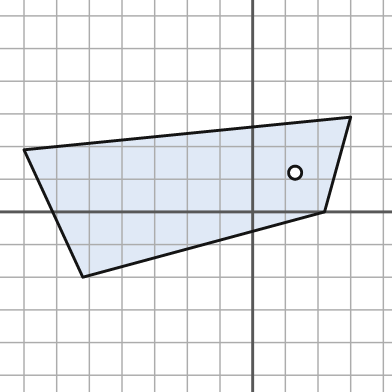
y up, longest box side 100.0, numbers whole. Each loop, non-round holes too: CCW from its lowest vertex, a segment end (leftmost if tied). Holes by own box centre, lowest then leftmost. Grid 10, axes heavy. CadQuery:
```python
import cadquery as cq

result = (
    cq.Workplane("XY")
    .moveTo(-52.0, -20.0)
    .lineTo(22.0, 0.0)
    .lineTo(30.0, 29.0)
    .lineTo(-70.0, 19.0)
    .close()
    .moveTo(13.0, 12.0)
    .circle(2.0)
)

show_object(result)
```